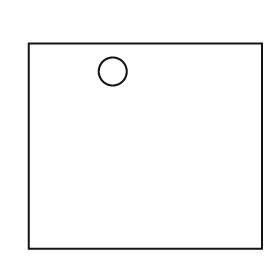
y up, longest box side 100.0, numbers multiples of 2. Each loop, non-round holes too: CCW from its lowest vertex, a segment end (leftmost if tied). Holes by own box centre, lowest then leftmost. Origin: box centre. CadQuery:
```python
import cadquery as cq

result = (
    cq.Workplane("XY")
    .moveTo(-50.0, -44.0)
    .lineTo(50.0, -44.0)
    .lineTo(50.0, 44.0)
    .lineTo(-50.0, 44.0)
    .close()
    .moveTo(-14.0, 32.0)
    .circle(6.0)
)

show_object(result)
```